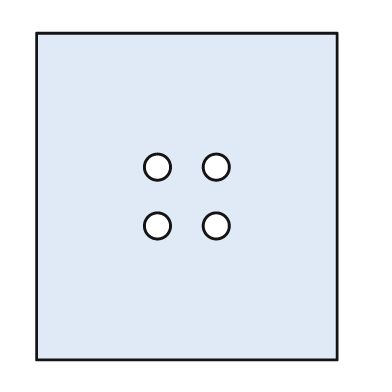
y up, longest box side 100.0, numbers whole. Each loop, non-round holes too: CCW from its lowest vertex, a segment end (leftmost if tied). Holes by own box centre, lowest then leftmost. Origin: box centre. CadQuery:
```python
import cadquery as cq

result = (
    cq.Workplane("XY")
    .moveTo(-46.0, -50.0)
    .lineTo(46.0, -50.0)
    .lineTo(46.0, 50.0)
    .lineTo(-46.0, 50.0)
    .close()
    .moveTo(-9.0, -9.0)
    .circle(4.0)
    .moveTo(9.0, -9.0)
    .circle(4.0)
    .moveTo(-9.0, 9.0)
    .circle(4.0)
    .moveTo(9.0, 9.0)
    .circle(4.0)
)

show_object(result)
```